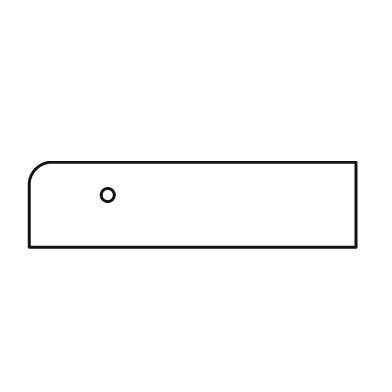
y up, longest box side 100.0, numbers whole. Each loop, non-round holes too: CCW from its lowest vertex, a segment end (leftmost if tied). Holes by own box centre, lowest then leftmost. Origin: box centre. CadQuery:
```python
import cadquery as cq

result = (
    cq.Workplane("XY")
    .moveTo(-50.0, -13.0)
    .lineTo(50.0, -13.0)
    .lineTo(50.0, 13.0)
    .lineTo(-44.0, 13.0)
    .threePointArc((-48.0, 11.0), (-50.0, 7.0))
    .close()
    .moveTo(-26.0, 3.0)
    .circle(2.0)
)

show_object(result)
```